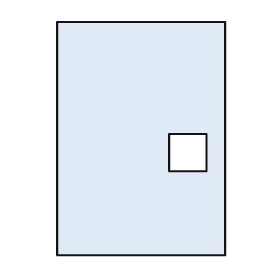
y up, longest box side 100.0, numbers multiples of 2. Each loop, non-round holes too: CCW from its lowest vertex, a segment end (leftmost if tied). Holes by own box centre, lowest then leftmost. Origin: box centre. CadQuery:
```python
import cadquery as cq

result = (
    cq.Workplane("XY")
    .moveTo(-36.0, -50.0)
    .lineTo(36.0, -50.0)
    .lineTo(36.0, 50.0)
    .lineTo(-36.0, 50.0)
    .close()
    .moveTo(12.0, -14.0)
    .lineTo(28.0, -14.0)
    .lineTo(28.0, 2.0)
    .lineTo(12.0, 2.0)
    .close()
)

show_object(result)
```